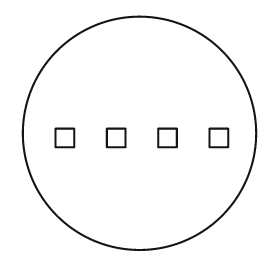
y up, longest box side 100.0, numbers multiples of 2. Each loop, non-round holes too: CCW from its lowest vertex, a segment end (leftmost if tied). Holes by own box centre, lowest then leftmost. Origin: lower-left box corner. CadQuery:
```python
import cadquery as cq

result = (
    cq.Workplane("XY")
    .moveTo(50.0, 50.0)
    .circle(50.0)
    .moveTo(14.0, 44.0)
    .lineTo(22.0, 44.0)
    .lineTo(22.0, 52.0)
    .lineTo(14.0, 52.0)
    .close()
    .moveTo(36.0, 44.0)
    .lineTo(44.0, 44.0)
    .lineTo(44.0, 52.0)
    .lineTo(36.0, 52.0)
    .close()
    .moveTo(58.0, 44.0)
    .lineTo(66.0, 44.0)
    .lineTo(66.0, 52.0)
    .lineTo(58.0, 52.0)
    .close()
    .moveTo(80.0, 44.0)
    .lineTo(88.0, 44.0)
    .lineTo(88.0, 52.0)
    .lineTo(80.0, 52.0)
    .close()
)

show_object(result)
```